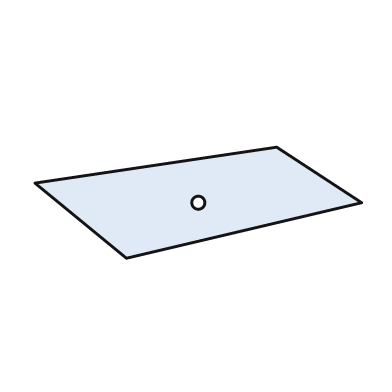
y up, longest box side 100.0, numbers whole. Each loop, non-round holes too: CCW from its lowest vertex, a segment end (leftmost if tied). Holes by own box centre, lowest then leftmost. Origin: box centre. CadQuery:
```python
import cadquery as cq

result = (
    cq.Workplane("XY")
    .moveTo(-22.0, -17.0)
    .lineTo(50.0, 0.0)
    .lineTo(24.0, 17.0)
    .lineTo(-50.0, 6.0)
    .close()
    .moveTo(0.0, 0.0)
    .circle(2.0)
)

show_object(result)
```